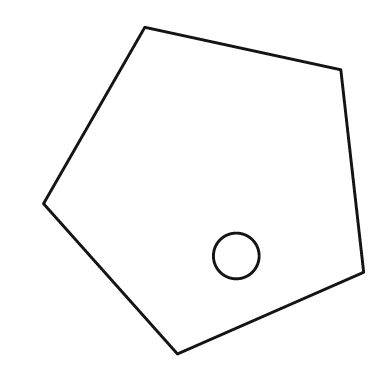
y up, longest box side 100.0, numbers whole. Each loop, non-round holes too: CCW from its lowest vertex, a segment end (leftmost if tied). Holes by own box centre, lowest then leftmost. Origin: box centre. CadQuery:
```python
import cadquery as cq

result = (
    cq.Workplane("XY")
    .moveTo(-8.0, -50.0)
    .lineTo(49.0, -25.0)
    .lineTo(42.0, 37.0)
    .lineTo(-18.0, 50.0)
    .lineTo(-49.0, -4.0)
    .close()
    .moveTo(10.0, -20.0)
    .circle(7.0)
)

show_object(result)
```